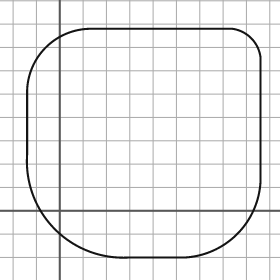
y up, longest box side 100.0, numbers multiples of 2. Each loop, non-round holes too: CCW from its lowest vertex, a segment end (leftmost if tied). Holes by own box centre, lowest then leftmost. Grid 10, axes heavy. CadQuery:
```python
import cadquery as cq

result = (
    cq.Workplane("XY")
    .moveTo(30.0, -20.0)
    .lineTo(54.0, -20.0)
    .threePointArc((76.0, -10.0), (86.0, 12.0))
    .lineTo(86.0, 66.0)
    .threePointArc((82.0, 74.0), (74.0, 78.0))
    .lineTo(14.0, 78.0)
    .threePointArc((-6.0, 70.0), (-14.0, 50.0))
    .lineTo(-14.0, 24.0)
    .threePointArc((-2.0, -8.0), (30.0, -20.0))
    .close()
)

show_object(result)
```